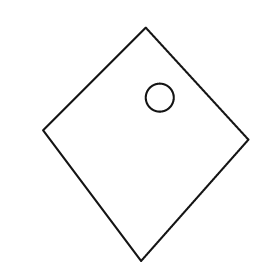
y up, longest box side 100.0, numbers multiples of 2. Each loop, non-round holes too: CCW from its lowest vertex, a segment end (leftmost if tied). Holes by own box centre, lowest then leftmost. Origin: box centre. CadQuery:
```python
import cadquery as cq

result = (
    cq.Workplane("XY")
    .moveTo(-2.0, -50.0)
    .lineTo(44.0, 2.0)
    .lineTo(0.0, 50.0)
    .lineTo(-44.0, 6.0)
    .close()
    .moveTo(6.0, 20.0)
    .circle(6.0)
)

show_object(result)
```